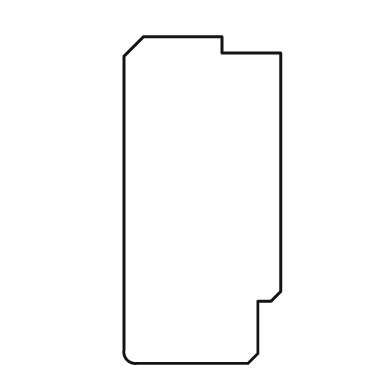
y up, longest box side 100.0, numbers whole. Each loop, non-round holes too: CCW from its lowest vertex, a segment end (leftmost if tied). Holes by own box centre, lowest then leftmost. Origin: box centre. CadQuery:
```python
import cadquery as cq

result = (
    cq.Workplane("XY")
    .moveTo(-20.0, -50.0)
    .lineTo(14.0, -50.0)
    .lineTo(17.0, -47.0)
    .lineTo(17.0, -31.0)
    .lineTo(21.0, -31.0)
    .lineTo(24.0, -28.0)
    .lineTo(24.0, 45.0)
    .lineTo(6.0, 45.0)
    .lineTo(6.0, 50.0)
    .lineTo(-18.0, 50.0)
    .lineTo(-24.0, 44.0)
    .lineTo(-24.0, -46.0)
    .threePointArc((-23.0, -49.0), (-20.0, -50.0))
    .close()
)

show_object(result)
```